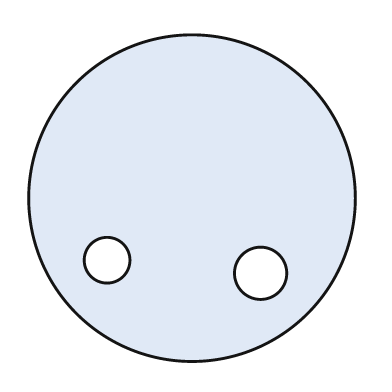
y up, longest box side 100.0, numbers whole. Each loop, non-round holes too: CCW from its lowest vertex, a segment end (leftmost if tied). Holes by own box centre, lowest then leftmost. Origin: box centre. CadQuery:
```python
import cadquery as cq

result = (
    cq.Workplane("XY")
    .moveTo(0.0, 0.0)
    .circle(50.0)
    .moveTo(21.0, -23.0)
    .circle(8.0)
    .moveTo(-26.0, -19.0)
    .circle(7.0)
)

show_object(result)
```